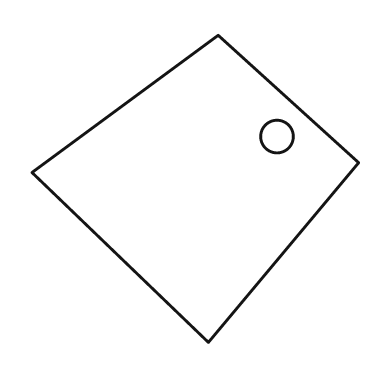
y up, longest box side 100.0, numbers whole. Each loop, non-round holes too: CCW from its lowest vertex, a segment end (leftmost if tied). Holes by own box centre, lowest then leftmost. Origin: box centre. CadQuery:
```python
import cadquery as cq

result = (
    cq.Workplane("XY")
    .moveTo(4.0, -47.0)
    .lineTo(50.0, 8.0)
    .lineTo(7.0, 47.0)
    .lineTo(-50.0, 5.0)
    .close()
    .moveTo(25.0, 16.0)
    .circle(5.0)
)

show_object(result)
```